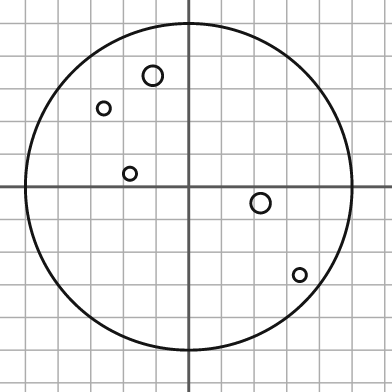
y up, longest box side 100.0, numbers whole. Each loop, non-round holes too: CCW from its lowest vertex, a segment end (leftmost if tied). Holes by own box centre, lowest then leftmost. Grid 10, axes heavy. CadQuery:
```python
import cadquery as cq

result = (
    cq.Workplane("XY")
    .moveTo(0.0, 0.0)
    .circle(50.0)
    .moveTo(34.0, -27.0)
    .circle(2.0)
    .moveTo(22.0, -5.0)
    .circle(3.0)
    .moveTo(-18.0, 4.0)
    .circle(2.0)
    .moveTo(-26.0, 24.0)
    .circle(2.0)
    .moveTo(-11.0, 34.0)
    .circle(3.0)
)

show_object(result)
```